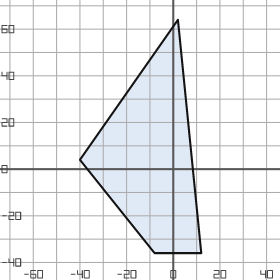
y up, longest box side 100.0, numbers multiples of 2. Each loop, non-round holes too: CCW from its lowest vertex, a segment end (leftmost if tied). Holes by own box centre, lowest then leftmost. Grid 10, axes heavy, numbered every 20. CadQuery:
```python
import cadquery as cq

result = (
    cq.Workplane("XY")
    .moveTo(-8.0, -36.0)
    .lineTo(12.0, -36.0)
    .lineTo(2.0, 64.0)
    .lineTo(-40.0, 4.0)
    .close()
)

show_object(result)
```